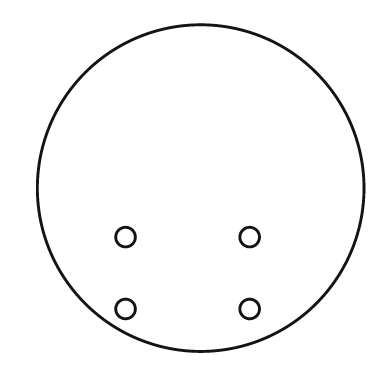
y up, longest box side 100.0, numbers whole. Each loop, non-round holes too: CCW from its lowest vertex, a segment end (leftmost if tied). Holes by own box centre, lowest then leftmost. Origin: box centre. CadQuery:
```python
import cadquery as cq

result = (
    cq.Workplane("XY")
    .moveTo(0.0, 0.0)
    .circle(50.0)
    .moveTo(-23.0, -37.0)
    .circle(3.0)
    .moveTo(15.0, -37.0)
    .circle(3.0)
    .moveTo(-23.0, -15.0)
    .circle(3.0)
    .moveTo(15.0, -15.0)
    .circle(3.0)
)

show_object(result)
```